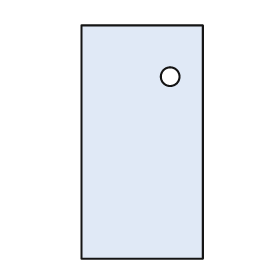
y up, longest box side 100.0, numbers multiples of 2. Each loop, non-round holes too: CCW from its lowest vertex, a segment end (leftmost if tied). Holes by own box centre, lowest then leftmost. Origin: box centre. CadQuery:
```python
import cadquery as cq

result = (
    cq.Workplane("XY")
    .moveTo(-26.0, -50.0)
    .lineTo(26.0, -50.0)
    .lineTo(26.0, 50.0)
    .lineTo(-26.0, 50.0)
    .close()
    .moveTo(12.0, 28.0)
    .circle(4.0)
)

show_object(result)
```